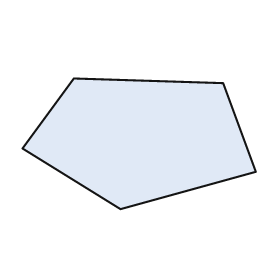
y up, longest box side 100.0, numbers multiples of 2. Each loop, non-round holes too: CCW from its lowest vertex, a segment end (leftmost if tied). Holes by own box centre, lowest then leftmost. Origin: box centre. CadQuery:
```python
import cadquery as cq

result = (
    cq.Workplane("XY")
    .moveTo(-8.0, -28.0)
    .lineTo(50.0, -12.0)
    .lineTo(36.0, 26.0)
    .lineTo(-28.0, 28.0)
    .lineTo(-50.0, -2.0)
    .close()
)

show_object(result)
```